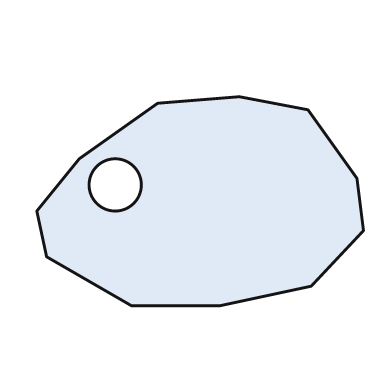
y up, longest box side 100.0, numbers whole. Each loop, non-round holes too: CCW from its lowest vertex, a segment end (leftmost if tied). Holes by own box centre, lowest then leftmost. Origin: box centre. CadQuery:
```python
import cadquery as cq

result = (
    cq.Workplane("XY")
    .moveTo(-21.0, -32.0)
    .lineTo(6.0, -32.0)
    .lineTo(34.0, -26.0)
    .lineTo(50.0, -9.0)
    .lineTo(48.0, 7.0)
    .lineTo(33.0, 28.0)
    .lineTo(12.0, 32.0)
    .lineTo(-13.0, 30.0)
    .lineTo(-37.0, 13.0)
    .lineTo(-50.0, -3.0)
    .lineTo(-47.0, -17.0)
    .close()
    .moveTo(-26.0, 5.0)
    .circle(8.0)
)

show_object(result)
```